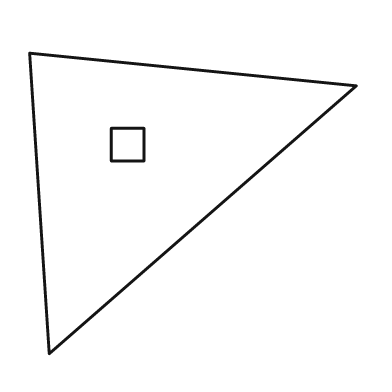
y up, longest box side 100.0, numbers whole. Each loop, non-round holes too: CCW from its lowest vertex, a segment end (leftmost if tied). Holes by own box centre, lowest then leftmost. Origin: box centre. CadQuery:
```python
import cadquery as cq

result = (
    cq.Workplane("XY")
    .moveTo(-44.0, -46.0)
    .lineTo(50.0, 36.0)
    .lineTo(-50.0, 46.0)
    .close()
    .moveTo(-25.0, 13.0)
    .lineTo(-15.0, 13.0)
    .lineTo(-15.0, 23.0)
    .lineTo(-25.0, 23.0)
    .close()
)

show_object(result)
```